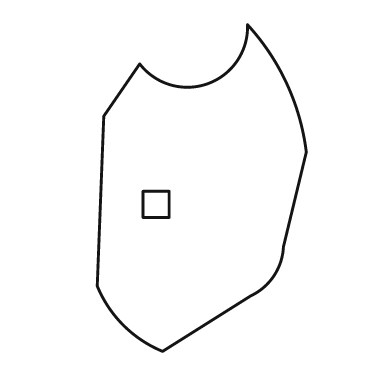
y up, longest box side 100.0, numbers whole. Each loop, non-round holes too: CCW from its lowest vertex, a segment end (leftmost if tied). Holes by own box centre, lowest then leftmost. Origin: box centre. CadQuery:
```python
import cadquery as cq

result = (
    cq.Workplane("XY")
    .moveTo(-12.0, -50.0)
    .lineTo(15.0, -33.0)
    .threePointArc((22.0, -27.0), (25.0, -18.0))
    .lineTo(32.0, 11.0)
    .threePointArc((26.0, 32.0), (14.0, 50.0))
    .threePointArc((2.0, 32.0), (-19.0, 38.0))
    .lineTo(-30.0, 22.0)
    .lineTo(-32.0, -30.0)
    .threePointArc((-24.0, -42.0), (-12.0, -50.0))
    .close()
    .moveTo(-18.0, -9.0)
    .lineTo(-10.0, -9.0)
    .lineTo(-10.0, -1.0)
    .lineTo(-18.0, -1.0)
    .close()
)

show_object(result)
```